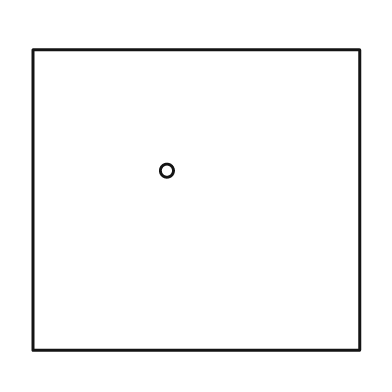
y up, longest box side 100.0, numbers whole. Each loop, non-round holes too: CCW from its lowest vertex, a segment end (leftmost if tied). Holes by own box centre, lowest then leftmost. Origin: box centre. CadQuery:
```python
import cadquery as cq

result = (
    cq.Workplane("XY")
    .moveTo(-50.0, -46.0)
    .lineTo(50.0, -46.0)
    .lineTo(50.0, 46.0)
    .lineTo(-50.0, 46.0)
    .close()
    .moveTo(-9.0, 9.0)
    .circle(2.0)
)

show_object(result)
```